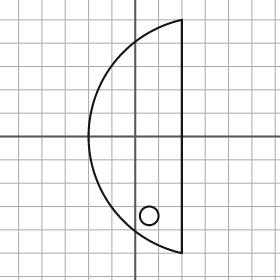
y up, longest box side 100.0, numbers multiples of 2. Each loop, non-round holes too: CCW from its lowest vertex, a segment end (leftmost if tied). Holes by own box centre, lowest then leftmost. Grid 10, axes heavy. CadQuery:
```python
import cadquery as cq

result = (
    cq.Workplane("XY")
    .moveTo(20.0, -50.0)
    .lineTo(20.0, 50.0)
    .threePointArc((-20.0, 0.0), (20.0, -50.0))
    .close()
    .moveTo(6.0, -34.0)
    .circle(4.0)
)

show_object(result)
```